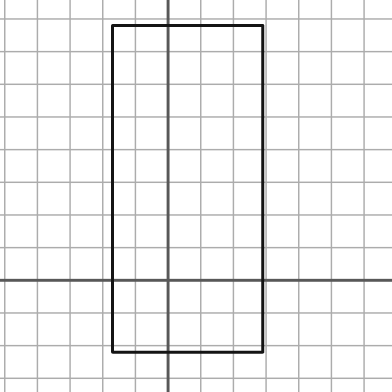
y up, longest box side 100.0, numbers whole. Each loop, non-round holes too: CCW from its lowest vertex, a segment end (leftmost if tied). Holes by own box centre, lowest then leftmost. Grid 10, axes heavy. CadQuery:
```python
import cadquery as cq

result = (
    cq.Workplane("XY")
    .moveTo(-17.0, -22.0)
    .lineTo(29.0, -22.0)
    .lineTo(29.0, 78.0)
    .lineTo(-17.0, 78.0)
    .close()
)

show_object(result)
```